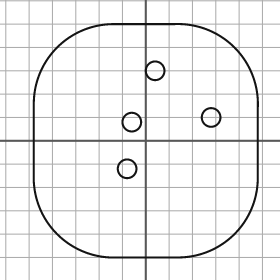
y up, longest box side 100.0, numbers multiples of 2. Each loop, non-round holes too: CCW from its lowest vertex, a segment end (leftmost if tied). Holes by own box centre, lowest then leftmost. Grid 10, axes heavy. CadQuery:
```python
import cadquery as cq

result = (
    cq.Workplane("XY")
    .moveTo(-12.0, -50.0)
    .lineTo(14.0, -50.0)
    .threePointArc((38.0, -40.0), (48.0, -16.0))
    .lineTo(48.0, 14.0)
    .threePointArc((38.0, 40.0), (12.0, 50.0))
    .lineTo(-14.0, 50.0)
    .threePointArc((-38.0, 40.0), (-48.0, 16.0))
    .lineTo(-48.0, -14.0)
    .threePointArc((-38.0, -40.0), (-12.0, -50.0))
    .close()
    .moveTo(-8.0, -12.0)
    .circle(4.0)
    .moveTo(-6.0, 8.0)
    .circle(4.0)
    .moveTo(28.0, 10.0)
    .circle(4.0)
    .moveTo(4.0, 30.0)
    .circle(4.0)
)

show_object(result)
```